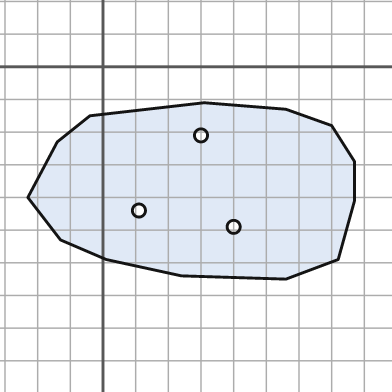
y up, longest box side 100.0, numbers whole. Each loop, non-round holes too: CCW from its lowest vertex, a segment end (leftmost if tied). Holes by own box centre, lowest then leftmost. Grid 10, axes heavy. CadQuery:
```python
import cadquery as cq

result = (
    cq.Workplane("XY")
    .moveTo(56.0, -65.0)
    .lineTo(72.0, -59.0)
    .lineTo(77.0, -41.0)
    .lineTo(77.0, -29.0)
    .lineTo(70.0, -18.0)
    .lineTo(56.0, -13.0)
    .lineTo(31.0, -11.0)
    .lineTo(-4.0, -15.0)
    .lineTo(-14.0, -23.0)
    .lineTo(-23.0, -40.0)
    .lineTo(-13.0, -53.0)
    .lineTo(1.0, -59.0)
    .lineTo(24.0, -64.0)
    .close()
    .moveTo(40.0, -49.0)
    .circle(2.0)
    .moveTo(11.0, -44.0)
    .circle(2.0)
    .moveTo(30.0, -21.0)
    .circle(2.0)
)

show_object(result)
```